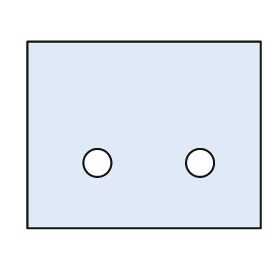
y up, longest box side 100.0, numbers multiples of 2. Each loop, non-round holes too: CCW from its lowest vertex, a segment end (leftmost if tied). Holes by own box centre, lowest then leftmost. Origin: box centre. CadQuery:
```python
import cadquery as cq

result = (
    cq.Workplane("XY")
    .moveTo(-50.0, -40.0)
    .lineTo(50.0, -40.0)
    .lineTo(50.0, 40.0)
    .lineTo(-50.0, 40.0)
    .close()
    .moveTo(-20.0, -12.0)
    .circle(6.0)
    .moveTo(24.0, -12.0)
    .circle(6.0)
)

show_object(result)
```